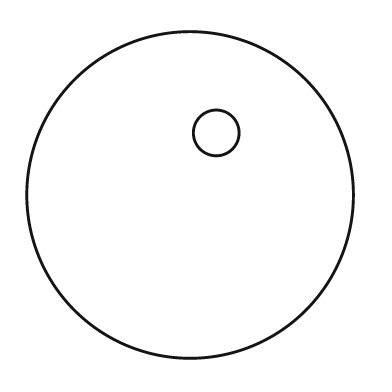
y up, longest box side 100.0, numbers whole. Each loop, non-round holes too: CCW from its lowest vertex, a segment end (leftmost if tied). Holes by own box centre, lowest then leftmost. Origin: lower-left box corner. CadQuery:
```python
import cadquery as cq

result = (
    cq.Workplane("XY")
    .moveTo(50.0, 50.0)
    .circle(50.0)
    .moveTo(58.0, 69.0)
    .circle(7.0)
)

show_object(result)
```